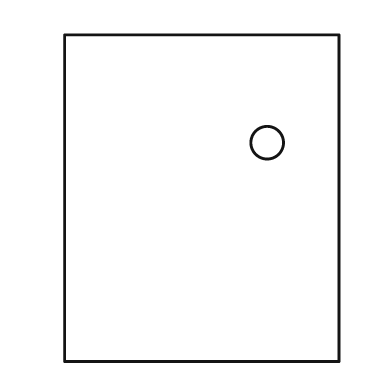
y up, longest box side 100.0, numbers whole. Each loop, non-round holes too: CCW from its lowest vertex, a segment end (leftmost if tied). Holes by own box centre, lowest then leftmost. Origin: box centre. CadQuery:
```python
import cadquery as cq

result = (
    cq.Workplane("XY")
    .moveTo(-42.0, -50.0)
    .lineTo(42.0, -50.0)
    .lineTo(42.0, 50.0)
    .lineTo(-42.0, 50.0)
    .close()
    .moveTo(20.0, 17.0)
    .circle(5.0)
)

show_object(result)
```